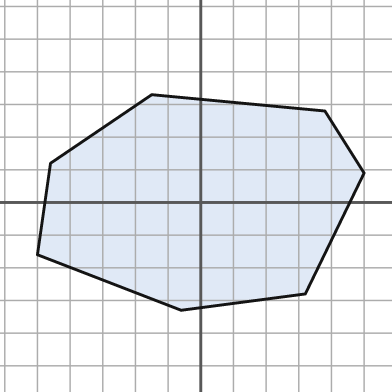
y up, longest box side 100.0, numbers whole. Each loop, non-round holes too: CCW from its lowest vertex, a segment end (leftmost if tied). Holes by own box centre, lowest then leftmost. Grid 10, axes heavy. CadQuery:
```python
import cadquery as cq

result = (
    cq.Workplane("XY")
    .moveTo(-6.0, -33.0)
    .lineTo(32.0, -28.0)
    .lineTo(50.0, 9.0)
    .lineTo(38.0, 28.0)
    .lineTo(-15.0, 33.0)
    .lineTo(-46.0, 12.0)
    .lineTo(-50.0, -16.0)
    .close()
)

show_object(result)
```